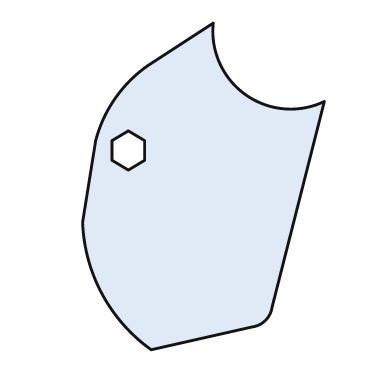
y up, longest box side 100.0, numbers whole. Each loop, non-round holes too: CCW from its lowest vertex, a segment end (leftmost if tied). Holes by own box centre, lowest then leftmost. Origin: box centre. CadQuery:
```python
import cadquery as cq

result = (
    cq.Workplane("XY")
    .moveTo(-16.0, -50.0)
    .lineTo(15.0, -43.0)
    .threePointArc((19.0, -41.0), (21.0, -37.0))
    .lineTo(37.0, 26.0)
    .threePointArc((13.0, 28.0), (3.0, 50.0))
    .lineTo(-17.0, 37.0)
    .threePointArc((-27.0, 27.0), (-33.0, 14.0))
    .lineTo(-37.0, -11.0)
    .threePointArc((-31.0, -33.0), (-16.0, -50.0))
    .close()
    .moveTo(-23.0, 5.0)
    .lineTo(-18.0, 8.0)
    .lineTo(-18.0, 14.0)
    .lineTo(-23.0, 17.0)
    .lineTo(-28.0, 14.0)
    .lineTo(-28.0, 8.0)
    .close()
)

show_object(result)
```